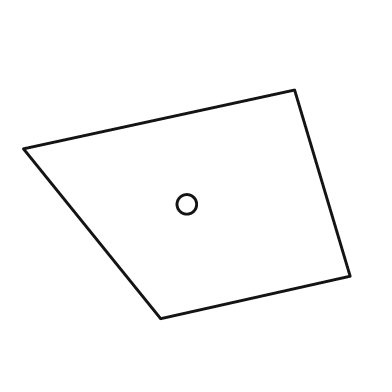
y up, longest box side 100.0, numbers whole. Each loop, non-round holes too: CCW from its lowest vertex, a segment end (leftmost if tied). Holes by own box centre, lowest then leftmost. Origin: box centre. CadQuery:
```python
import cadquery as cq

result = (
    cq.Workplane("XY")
    .moveTo(-8.0, -35.0)
    .lineTo(50.0, -22.0)
    .lineTo(33.0, 35.0)
    .lineTo(-50.0, 17.0)
    .close()
    .moveTo(0.0, 0.0)
    .circle(3.0)
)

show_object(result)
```